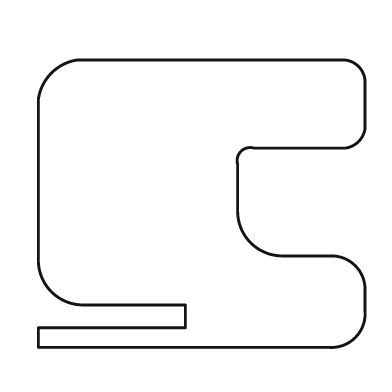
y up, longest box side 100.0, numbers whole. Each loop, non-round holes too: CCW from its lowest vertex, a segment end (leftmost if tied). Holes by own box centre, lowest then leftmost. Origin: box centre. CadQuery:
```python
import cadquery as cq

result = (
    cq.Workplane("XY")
    .moveTo(-50.0, -44.0)
    .lineTo(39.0, -44.0)
    .threePointArc((47.0, -41.0), (50.0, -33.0))
    .lineTo(50.0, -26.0)
    .threePointArc((47.0, -19.0), (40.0, -16.0))
    .lineTo(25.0, -16.0)
    .threePointArc((15.0, -12.0), (11.0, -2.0))
    .lineTo(11.0, 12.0)
    .threePointArc((12.0, 16.0), (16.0, 17.0))
    .lineTo(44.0, 17.0)
    .threePointArc((48.0, 19.0), (50.0, 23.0))
    .lineTo(50.0, 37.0)
    .threePointArc((48.0, 42.0), (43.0, 44.0))
    .lineTo(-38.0, 44.0)
    .threePointArc((-46.0, 40.0), (-50.0, 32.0))
    .lineTo(-50.0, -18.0)
    .threePointArc((-46.0, -27.0), (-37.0, -31.0))
    .lineTo(-5.0, -31.0)
    .lineTo(-5.0, -38.0)
    .lineTo(-50.0, -38.0)
    .close()
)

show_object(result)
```